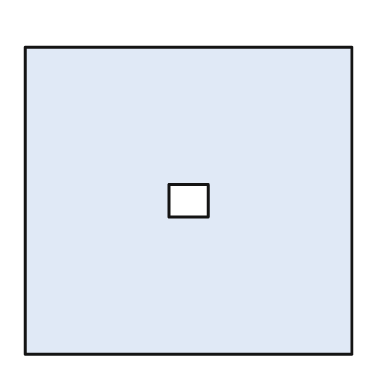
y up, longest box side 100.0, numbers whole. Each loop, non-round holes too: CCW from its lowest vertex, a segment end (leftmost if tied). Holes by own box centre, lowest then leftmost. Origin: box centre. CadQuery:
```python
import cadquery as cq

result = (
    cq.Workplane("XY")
    .moveTo(-50.0, -47.0)
    .lineTo(50.0, -47.0)
    .lineTo(50.0, 47.0)
    .lineTo(-50.0, 47.0)
    .close()
    .moveTo(-6.0, -5.0)
    .lineTo(6.0, -5.0)
    .lineTo(6.0, 5.0)
    .lineTo(-6.0, 5.0)
    .close()
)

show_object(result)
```